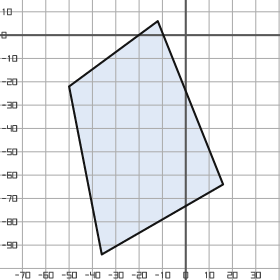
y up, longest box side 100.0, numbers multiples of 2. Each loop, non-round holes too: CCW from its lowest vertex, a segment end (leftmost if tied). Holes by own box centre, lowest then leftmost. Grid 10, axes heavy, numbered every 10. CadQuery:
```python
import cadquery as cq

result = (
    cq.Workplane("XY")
    .moveTo(-36.0, -94.0)
    .lineTo(16.0, -64.0)
    .lineTo(-12.0, 6.0)
    .lineTo(-50.0, -22.0)
    .close()
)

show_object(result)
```